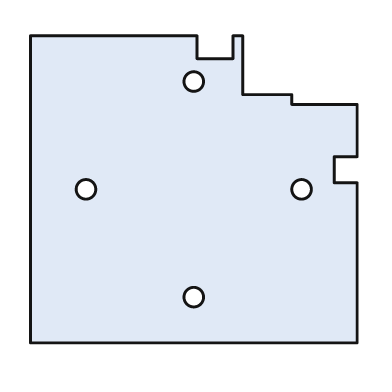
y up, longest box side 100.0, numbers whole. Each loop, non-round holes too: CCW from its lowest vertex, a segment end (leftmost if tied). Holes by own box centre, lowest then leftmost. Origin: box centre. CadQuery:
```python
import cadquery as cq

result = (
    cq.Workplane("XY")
    .moveTo(-50.0, -47.0)
    .lineTo(50.0, -47.0)
    .lineTo(50.0, 2.0)
    .lineTo(43.0, 2.0)
    .lineTo(43.0, 10.0)
    .lineTo(50.0, 10.0)
    .lineTo(50.0, 26.0)
    .lineTo(30.0, 26.0)
    .lineTo(30.0, 29.0)
    .lineTo(15.0, 29.0)
    .lineTo(15.0, 47.0)
    .lineTo(12.0, 47.0)
    .lineTo(12.0, 40.0)
    .lineTo(1.0, 40.0)
    .lineTo(1.0, 47.0)
    .lineTo(-50.0, 47.0)
    .close()
    .moveTo(0.0, -33.0)
    .circle(3.0)
    .moveTo(-33.0, 0.0)
    .circle(3.0)
    .moveTo(33.0, 0.0)
    .circle(3.0)
    .moveTo(0.0, 33.0)
    .circle(3.0)
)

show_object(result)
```